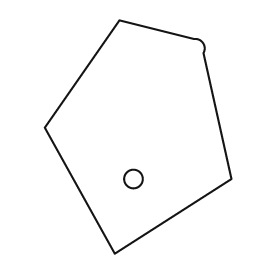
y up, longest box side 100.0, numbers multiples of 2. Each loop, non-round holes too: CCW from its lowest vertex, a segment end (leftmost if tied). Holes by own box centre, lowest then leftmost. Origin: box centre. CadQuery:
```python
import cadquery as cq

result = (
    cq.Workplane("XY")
    .moveTo(-10.0, -50.0)
    .lineTo(40.0, -18.0)
    .lineTo(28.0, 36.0)
    .threePointArc((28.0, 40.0), (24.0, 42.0))
    .lineTo(-8.0, 50.0)
    .lineTo(-40.0, 4.0)
    .close()
    .moveTo(-2.0, -18.0)
    .circle(4.0)
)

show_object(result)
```